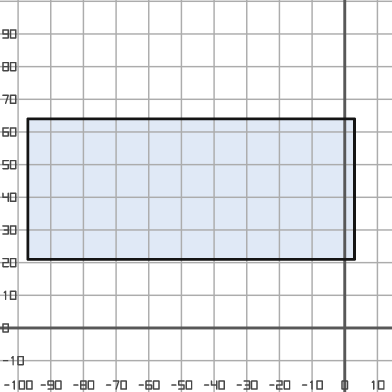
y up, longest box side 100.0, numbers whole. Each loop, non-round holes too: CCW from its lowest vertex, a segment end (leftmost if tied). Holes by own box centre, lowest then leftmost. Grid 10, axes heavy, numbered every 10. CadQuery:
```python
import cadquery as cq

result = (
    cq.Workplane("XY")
    .moveTo(-97.0, 21.0)
    .lineTo(3.0, 21.0)
    .lineTo(3.0, 64.0)
    .lineTo(-97.0, 64.0)
    .close()
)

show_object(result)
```